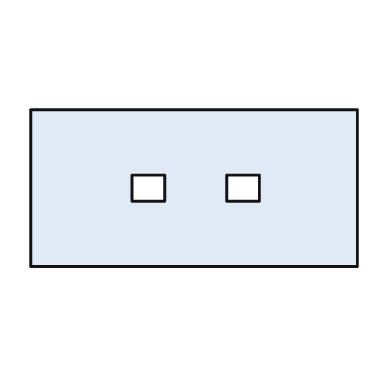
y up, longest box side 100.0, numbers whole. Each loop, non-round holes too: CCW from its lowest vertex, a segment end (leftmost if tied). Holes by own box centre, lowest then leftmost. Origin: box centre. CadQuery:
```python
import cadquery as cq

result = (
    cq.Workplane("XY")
    .moveTo(-50.0, -24.0)
    .lineTo(50.0, -24.0)
    .lineTo(50.0, 24.0)
    .lineTo(-50.0, 24.0)
    .close()
    .moveTo(-19.0, -4.0)
    .lineTo(-9.0, -4.0)
    .lineTo(-9.0, 4.0)
    .lineTo(-19.0, 4.0)
    .close()
    .moveTo(10.0, -4.0)
    .lineTo(20.0, -4.0)
    .lineTo(20.0, 4.0)
    .lineTo(10.0, 4.0)
    .close()
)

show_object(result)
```